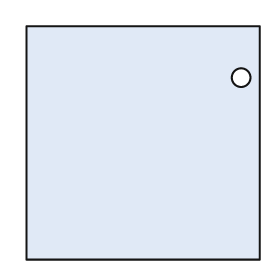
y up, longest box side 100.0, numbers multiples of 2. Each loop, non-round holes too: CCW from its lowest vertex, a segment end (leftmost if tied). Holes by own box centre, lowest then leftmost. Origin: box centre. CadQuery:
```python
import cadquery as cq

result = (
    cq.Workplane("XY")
    .moveTo(-50.0, -50.0)
    .lineTo(50.0, -50.0)
    .lineTo(50.0, 50.0)
    .lineTo(-50.0, 50.0)
    .close()
    .moveTo(42.0, 28.0)
    .circle(4.0)
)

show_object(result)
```